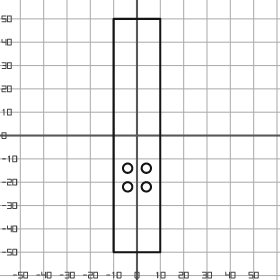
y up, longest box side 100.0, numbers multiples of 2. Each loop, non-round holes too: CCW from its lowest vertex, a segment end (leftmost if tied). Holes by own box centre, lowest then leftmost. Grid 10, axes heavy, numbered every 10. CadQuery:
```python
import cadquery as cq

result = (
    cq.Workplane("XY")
    .moveTo(-10.0, -50.0)
    .lineTo(10.0, -50.0)
    .lineTo(10.0, 50.0)
    .lineTo(-10.0, 50.0)
    .close()
    .moveTo(-4.0, -22.0)
    .circle(2.0)
    .moveTo(4.0, -22.0)
    .circle(2.0)
    .moveTo(-4.0, -14.0)
    .circle(2.0)
    .moveTo(4.0, -14.0)
    .circle(2.0)
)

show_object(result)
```